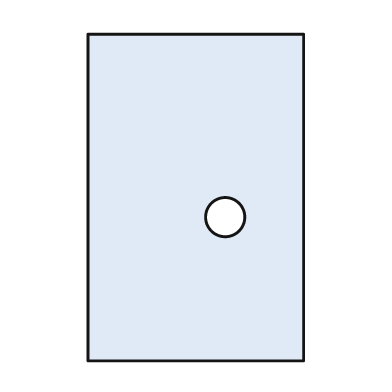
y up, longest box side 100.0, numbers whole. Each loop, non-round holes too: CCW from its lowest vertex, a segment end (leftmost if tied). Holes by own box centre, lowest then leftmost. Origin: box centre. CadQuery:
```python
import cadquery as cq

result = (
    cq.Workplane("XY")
    .moveTo(-33.0, -50.0)
    .lineTo(33.0, -50.0)
    .lineTo(33.0, 50.0)
    .lineTo(-33.0, 50.0)
    .close()
    .moveTo(9.0, -6.0)
    .circle(6.0)
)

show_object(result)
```